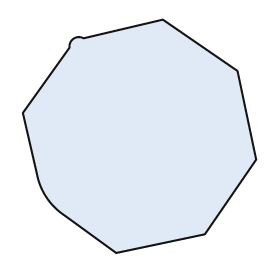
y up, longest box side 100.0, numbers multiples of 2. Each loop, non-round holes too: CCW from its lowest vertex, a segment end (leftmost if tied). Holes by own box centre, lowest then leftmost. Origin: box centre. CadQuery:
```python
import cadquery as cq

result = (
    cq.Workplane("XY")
    .moveTo(-10.0, -50.0)
    .lineTo(28.0, -42.0)
    .lineTo(50.0, -10.0)
    .lineTo(42.0, 28.0)
    .lineTo(10.0, 50.0)
    .lineTo(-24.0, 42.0)
    .threePointArc((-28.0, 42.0), (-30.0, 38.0))
    .lineTo(-50.0, 10.0)
    .lineTo(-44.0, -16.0)
    .threePointArc((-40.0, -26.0), (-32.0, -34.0))
    .close()
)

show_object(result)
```